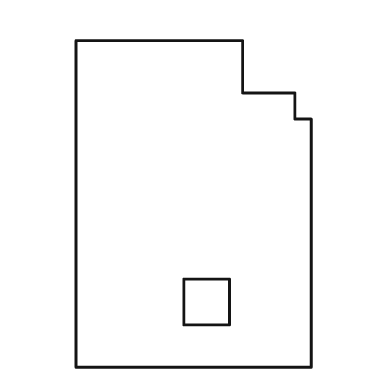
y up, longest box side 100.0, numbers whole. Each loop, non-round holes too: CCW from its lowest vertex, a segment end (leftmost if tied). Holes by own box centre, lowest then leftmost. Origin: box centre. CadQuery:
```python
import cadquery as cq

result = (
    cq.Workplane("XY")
    .moveTo(-36.0, -50.0)
    .lineTo(36.0, -50.0)
    .lineTo(36.0, 26.0)
    .lineTo(31.0, 26.0)
    .lineTo(31.0, 34.0)
    .lineTo(15.0, 34.0)
    .lineTo(15.0, 50.0)
    .lineTo(-36.0, 50.0)
    .close()
    .moveTo(-3.0, -37.0)
    .lineTo(11.0, -37.0)
    .lineTo(11.0, -23.0)
    .lineTo(-3.0, -23.0)
    .close()
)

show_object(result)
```